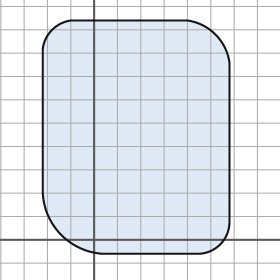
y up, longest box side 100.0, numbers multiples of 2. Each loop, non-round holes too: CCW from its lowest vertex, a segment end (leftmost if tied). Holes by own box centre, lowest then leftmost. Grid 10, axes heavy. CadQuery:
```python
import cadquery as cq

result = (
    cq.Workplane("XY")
    .moveTo(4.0, -6.0)
    .lineTo(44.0, -6.0)
    .threePointArc((54.0, -2.0), (58.0, 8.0))
    .lineTo(58.0, 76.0)
    .threePointArc((52.0, 88.0), (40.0, 94.0))
    .lineTo(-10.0, 94.0)
    .threePointArc((-18.0, 90.0), (-22.0, 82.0))
    .lineTo(-22.0, 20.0)
    .threePointArc((-14.0, 2.0), (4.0, -6.0))
    .close()
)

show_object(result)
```